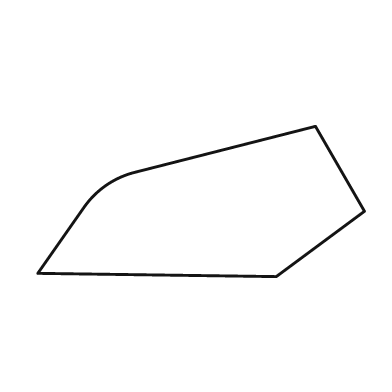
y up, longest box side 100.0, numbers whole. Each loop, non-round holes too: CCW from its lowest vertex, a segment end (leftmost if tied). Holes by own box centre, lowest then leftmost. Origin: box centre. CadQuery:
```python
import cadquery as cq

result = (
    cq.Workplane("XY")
    .moveTo(23.0, -23.0)
    .lineTo(50.0, -3.0)
    .lineTo(35.0, 23.0)
    .lineTo(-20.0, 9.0)
    .threePointArc((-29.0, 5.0), (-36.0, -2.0))
    .lineTo(-50.0, -22.0)
    .close()
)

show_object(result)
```